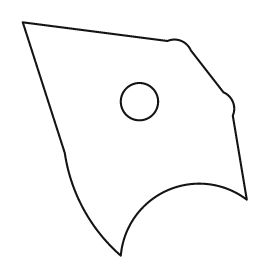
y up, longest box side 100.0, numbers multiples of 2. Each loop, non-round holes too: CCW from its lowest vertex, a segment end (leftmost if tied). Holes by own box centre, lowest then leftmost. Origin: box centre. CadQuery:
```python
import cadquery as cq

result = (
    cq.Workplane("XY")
    .moveTo(-6.0, -50.0)
    .threePointArc((14.0, -22.0), (48.0, -26.0))
    .lineTo(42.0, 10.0)
    .threePointArc((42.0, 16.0), (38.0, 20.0))
    .lineTo(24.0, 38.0)
    .threePointArc((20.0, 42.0), (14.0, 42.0))
    .lineTo(-48.0, 50.0)
    .lineTo(-30.0, -6.0)
    .threePointArc((-22.0, -30.0), (-6.0, -50.0))
    .close()
    .moveTo(2.0, 16.0)
    .circle(8.0)
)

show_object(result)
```